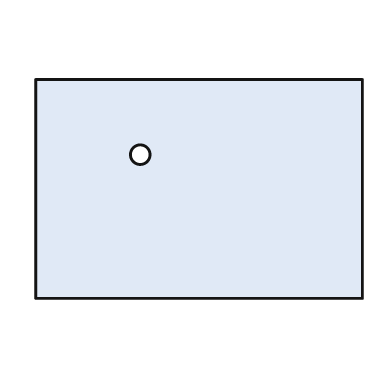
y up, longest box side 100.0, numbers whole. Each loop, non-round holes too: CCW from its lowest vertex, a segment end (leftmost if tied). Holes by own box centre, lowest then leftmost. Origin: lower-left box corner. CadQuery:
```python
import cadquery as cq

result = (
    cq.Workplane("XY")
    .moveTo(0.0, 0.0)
    .lineTo(100.0, 0.0)
    .lineTo(100.0, 67.0)
    .lineTo(0.0, 67.0)
    .close()
    .moveTo(32.0, 44.0)
    .circle(3.0)
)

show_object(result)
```